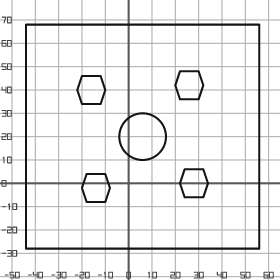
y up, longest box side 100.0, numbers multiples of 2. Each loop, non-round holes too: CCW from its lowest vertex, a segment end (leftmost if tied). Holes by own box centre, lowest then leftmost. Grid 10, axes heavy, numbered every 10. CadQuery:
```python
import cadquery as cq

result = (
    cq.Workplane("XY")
    .moveTo(-44.0, -28.0)
    .lineTo(56.0, -28.0)
    .lineTo(56.0, 68.0)
    .lineTo(-44.0, 68.0)
    .close()
    .moveTo(-18.0, -8.0)
    .lineTo(-10.0, -8.0)
    .lineTo(-8.0, -2.0)
    .lineTo(-10.0, 4.0)
    .lineTo(-18.0, 4.0)
    .lineTo(-20.0, -2.0)
    .close()
    .moveTo(24.0, -6.0)
    .lineTo(32.0, -6.0)
    .lineTo(34.0, 0.0)
    .lineTo(32.0, 6.0)
    .lineTo(24.0, 6.0)
    .lineTo(22.0, 0.0)
    .close()
    .moveTo(6.0, 20.0)
    .circle(10.0)
    .moveTo(-20.0, 34.0)
    .lineTo(-12.0, 34.0)
    .lineTo(-10.0, 40.0)
    .lineTo(-12.0, 46.0)
    .lineTo(-20.0, 46.0)
    .lineTo(-22.0, 40.0)
    .close()
    .moveTo(22.0, 36.0)
    .lineTo(30.0, 36.0)
    .lineTo(32.0, 42.0)
    .lineTo(30.0, 48.0)
    .lineTo(22.0, 48.0)
    .lineTo(20.0, 42.0)
    .close()
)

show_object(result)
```